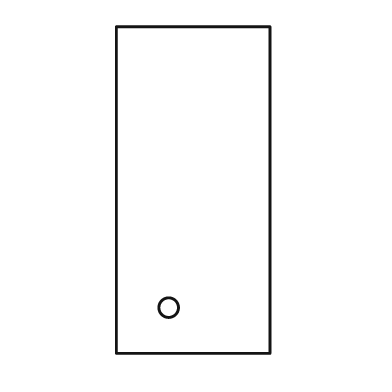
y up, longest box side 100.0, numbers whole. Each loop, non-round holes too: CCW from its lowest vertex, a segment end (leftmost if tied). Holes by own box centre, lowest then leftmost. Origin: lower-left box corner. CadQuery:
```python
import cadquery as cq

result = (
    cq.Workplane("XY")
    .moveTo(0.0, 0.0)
    .lineTo(47.0, 0.0)
    .lineTo(47.0, 100.0)
    .lineTo(0.0, 100.0)
    .close()
    .moveTo(16.0, 14.0)
    .circle(3.0)
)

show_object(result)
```